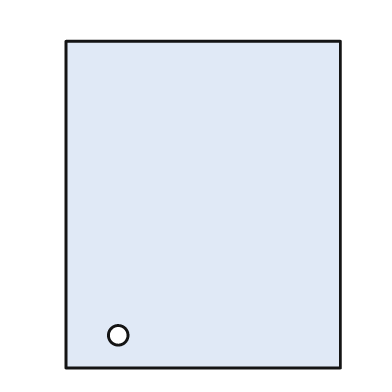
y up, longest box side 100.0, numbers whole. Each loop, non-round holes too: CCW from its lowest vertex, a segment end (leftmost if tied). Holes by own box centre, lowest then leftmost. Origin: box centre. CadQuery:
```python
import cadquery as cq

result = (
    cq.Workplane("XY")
    .moveTo(-42.0, -50.0)
    .lineTo(42.0, -50.0)
    .lineTo(42.0, 50.0)
    .lineTo(-42.0, 50.0)
    .close()
    .moveTo(-26.0, -40.0)
    .circle(3.0)
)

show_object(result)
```